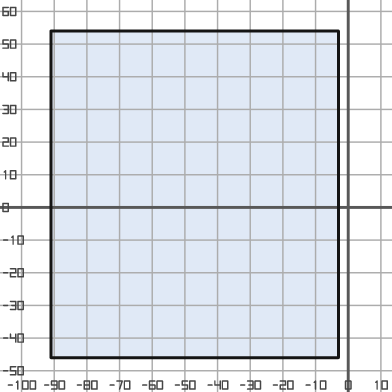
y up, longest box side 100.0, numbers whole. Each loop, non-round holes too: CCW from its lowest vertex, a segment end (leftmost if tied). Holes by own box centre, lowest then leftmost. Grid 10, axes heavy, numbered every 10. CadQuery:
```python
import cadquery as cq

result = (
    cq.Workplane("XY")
    .moveTo(-91.0, -46.0)
    .lineTo(-3.0, -46.0)
    .lineTo(-3.0, 54.0)
    .lineTo(-91.0, 54.0)
    .close()
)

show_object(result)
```